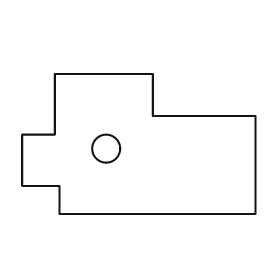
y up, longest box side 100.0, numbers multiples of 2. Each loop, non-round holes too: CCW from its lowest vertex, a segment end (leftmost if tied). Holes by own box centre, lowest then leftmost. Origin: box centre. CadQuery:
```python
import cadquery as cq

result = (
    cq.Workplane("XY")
    .moveTo(-34.0, -30.0)
    .lineTo(50.0, -30.0)
    .lineTo(50.0, 12.0)
    .lineTo(6.0, 12.0)
    .lineTo(6.0, 30.0)
    .lineTo(-36.0, 30.0)
    .lineTo(-36.0, 4.0)
    .lineTo(-50.0, 4.0)
    .lineTo(-50.0, -18.0)
    .lineTo(-34.0, -18.0)
    .close()
    .moveTo(-14.0, -2.0)
    .circle(6.0)
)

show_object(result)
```